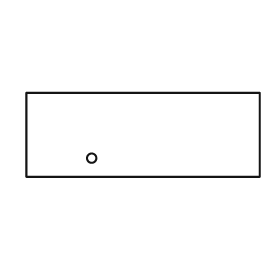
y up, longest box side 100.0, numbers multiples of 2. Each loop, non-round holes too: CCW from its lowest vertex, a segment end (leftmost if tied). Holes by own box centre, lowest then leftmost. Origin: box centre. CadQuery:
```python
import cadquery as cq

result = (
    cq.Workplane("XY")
    .moveTo(-50.0, -18.0)
    .lineTo(50.0, -18.0)
    .lineTo(50.0, 18.0)
    .lineTo(-50.0, 18.0)
    .close()
    .moveTo(-22.0, -10.0)
    .circle(2.0)
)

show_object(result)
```